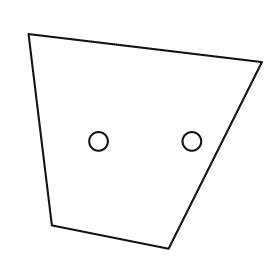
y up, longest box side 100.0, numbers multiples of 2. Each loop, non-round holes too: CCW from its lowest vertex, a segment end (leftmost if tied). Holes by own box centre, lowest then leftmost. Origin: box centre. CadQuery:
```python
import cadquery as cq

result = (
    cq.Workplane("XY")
    .moveTo(10.0, -46.0)
    .lineTo(50.0, 34.0)
    .lineTo(-50.0, 46.0)
    .lineTo(-40.0, -36.0)
    .close()
    .moveTo(-20.0, 0.0)
    .circle(4.0)
    .moveTo(20.0, 0.0)
    .circle(4.0)
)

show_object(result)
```